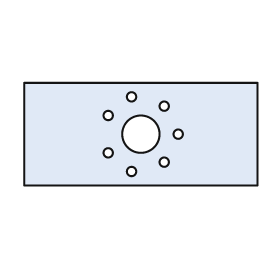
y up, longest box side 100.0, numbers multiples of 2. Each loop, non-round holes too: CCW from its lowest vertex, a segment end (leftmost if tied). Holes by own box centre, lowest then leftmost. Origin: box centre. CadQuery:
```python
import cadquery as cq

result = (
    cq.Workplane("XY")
    .moveTo(-50.0, -22.0)
    .lineTo(50.0, -22.0)
    .lineTo(50.0, 22.0)
    .lineTo(-50.0, 22.0)
    .close()
    .moveTo(-4.0, -16.0)
    .circle(2.0)
    .moveTo(10.0, -12.0)
    .circle(2.0)
    .moveTo(-14.0, -8.0)
    .circle(2.0)
    .moveTo(0.0, 0.0)
    .circle(8.0)
    .moveTo(16.0, 0.0)
    .circle(2.0)
    .moveTo(-14.0, 8.0)
    .circle(2.0)
    .moveTo(10.0, 12.0)
    .circle(2.0)
    .moveTo(-4.0, 16.0)
    .circle(2.0)
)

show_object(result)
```